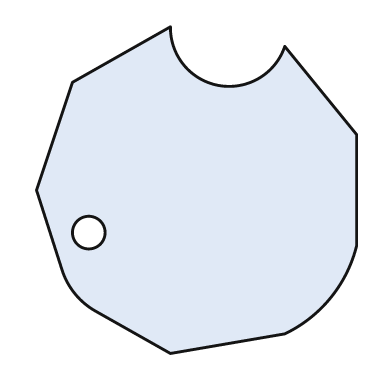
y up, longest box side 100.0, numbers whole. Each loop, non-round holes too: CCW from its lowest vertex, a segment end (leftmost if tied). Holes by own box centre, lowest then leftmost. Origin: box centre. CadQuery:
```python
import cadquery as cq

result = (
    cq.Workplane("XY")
    .moveTo(-8.0, -50.0)
    .lineTo(27.0, -44.0)
    .threePointArc((41.0, -33.0), (49.0, -17.0))
    .lineTo(49.0, 17.0)
    .lineTo(27.0, 44.0)
    .threePointArc((7.0, 32.0), (-8.0, 50.0))
    .lineTo(-38.0, 33.0)
    .lineTo(-49.0, 0.0)
    .lineTo(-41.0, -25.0)
    .threePointArc((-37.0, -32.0), (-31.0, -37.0))
    .close()
    .moveTo(-33.0, -13.0)
    .circle(5.0)
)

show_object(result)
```